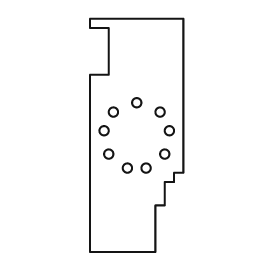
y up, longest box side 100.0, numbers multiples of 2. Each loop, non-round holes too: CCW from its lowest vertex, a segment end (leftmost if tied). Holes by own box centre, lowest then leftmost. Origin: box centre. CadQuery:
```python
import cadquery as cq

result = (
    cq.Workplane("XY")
    .moveTo(-20.0, -50.0)
    .lineTo(8.0, -50.0)
    .lineTo(8.0, -30.0)
    .lineTo(12.0, -30.0)
    .lineTo(12.0, -20.0)
    .lineTo(16.0, -20.0)
    .lineTo(16.0, -16.0)
    .lineTo(20.0, -16.0)
    .lineTo(20.0, 50.0)
    .lineTo(-20.0, 50.0)
    .lineTo(-20.0, 46.0)
    .lineTo(-12.0, 46.0)
    .lineTo(-12.0, 26.0)
    .lineTo(-20.0, 26.0)
    .close()
    .moveTo(-4.0, -14.0)
    .circle(2.0)
    .moveTo(4.0, -14.0)
    .circle(2.0)
    .moveTo(-12.0, -8.0)
    .circle(2.0)
    .moveTo(12.0, -8.0)
    .circle(2.0)
    .moveTo(-14.0, 2.0)
    .circle(2.0)
    .moveTo(14.0, 2.0)
    .circle(2.0)
    .moveTo(-10.0, 10.0)
    .circle(2.0)
    .moveTo(10.0, 10.0)
    .circle(2.0)
    .moveTo(0.0, 14.0)
    .circle(2.0)
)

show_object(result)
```